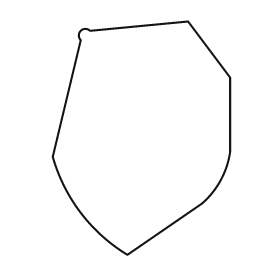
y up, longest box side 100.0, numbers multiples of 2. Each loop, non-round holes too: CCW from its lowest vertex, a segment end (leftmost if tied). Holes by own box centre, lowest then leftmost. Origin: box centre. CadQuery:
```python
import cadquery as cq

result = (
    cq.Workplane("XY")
    .moveTo(-6.0, -50.0)
    .lineTo(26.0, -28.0)
    .threePointArc((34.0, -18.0), (38.0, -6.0))
    .lineTo(38.0, 26.0)
    .lineTo(20.0, 50.0)
    .lineTo(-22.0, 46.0)
    .threePointArc((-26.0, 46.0), (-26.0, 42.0))
    .lineTo(-38.0, -8.0)
    .threePointArc((-26.0, -32.0), (-6.0, -50.0))
    .close()
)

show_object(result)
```